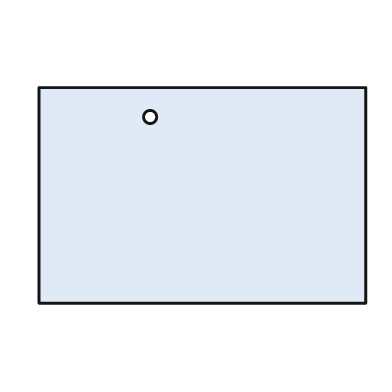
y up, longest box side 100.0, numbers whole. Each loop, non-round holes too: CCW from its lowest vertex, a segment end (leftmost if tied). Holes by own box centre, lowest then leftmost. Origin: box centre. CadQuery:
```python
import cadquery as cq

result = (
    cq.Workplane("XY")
    .moveTo(-50.0, -33.0)
    .lineTo(50.0, -33.0)
    .lineTo(50.0, 33.0)
    .lineTo(-50.0, 33.0)
    .close()
    .moveTo(-16.0, 24.0)
    .circle(2.0)
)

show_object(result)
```